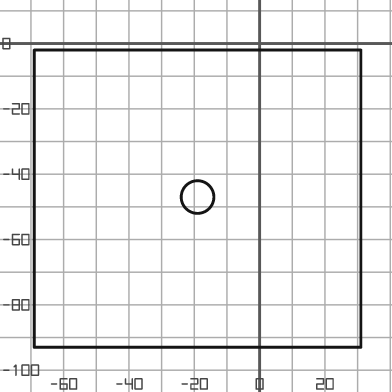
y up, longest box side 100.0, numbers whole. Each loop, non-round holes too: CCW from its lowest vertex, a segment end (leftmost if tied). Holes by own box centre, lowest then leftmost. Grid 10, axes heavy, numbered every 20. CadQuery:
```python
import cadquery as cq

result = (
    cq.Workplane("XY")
    .moveTo(-69.0, -93.0)
    .lineTo(31.0, -93.0)
    .lineTo(31.0, -2.0)
    .lineTo(-69.0, -2.0)
    .close()
    .moveTo(-19.0, -47.0)
    .circle(5.0)
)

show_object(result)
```